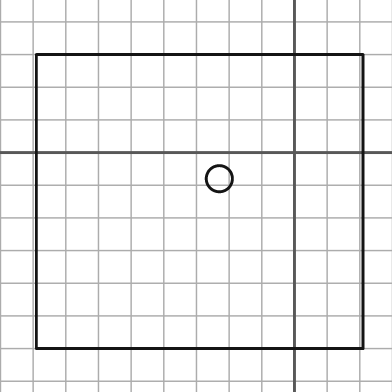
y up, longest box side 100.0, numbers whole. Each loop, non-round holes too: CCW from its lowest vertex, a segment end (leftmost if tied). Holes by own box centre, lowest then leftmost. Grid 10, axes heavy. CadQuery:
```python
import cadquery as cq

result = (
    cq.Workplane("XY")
    .moveTo(-79.0, -60.0)
    .lineTo(21.0, -60.0)
    .lineTo(21.0, 30.0)
    .lineTo(-79.0, 30.0)
    .close()
    .moveTo(-23.0, -8.0)
    .circle(4.0)
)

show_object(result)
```